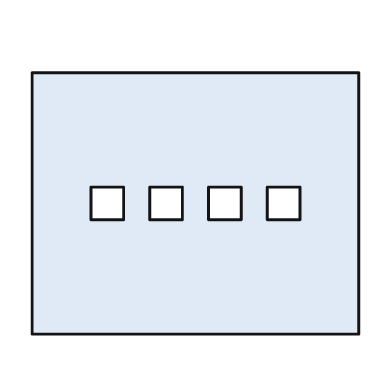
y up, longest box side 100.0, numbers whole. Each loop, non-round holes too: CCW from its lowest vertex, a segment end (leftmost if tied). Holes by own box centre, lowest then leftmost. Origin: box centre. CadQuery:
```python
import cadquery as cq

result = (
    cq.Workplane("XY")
    .moveTo(-50.0, -40.0)
    .lineTo(50.0, -40.0)
    .lineTo(50.0, 40.0)
    .lineTo(-50.0, 40.0)
    .close()
    .moveTo(-32.0, -5.0)
    .lineTo(-22.0, -5.0)
    .lineTo(-22.0, 5.0)
    .lineTo(-32.0, 5.0)
    .close()
    .moveTo(-14.0, -5.0)
    .lineTo(-4.0, -5.0)
    .lineTo(-4.0, 5.0)
    .lineTo(-14.0, 5.0)
    .close()
    .moveTo(4.0, -5.0)
    .lineTo(14.0, -5.0)
    .lineTo(14.0, 5.0)
    .lineTo(4.0, 5.0)
    .close()
    .moveTo(22.0, -5.0)
    .lineTo(32.0, -5.0)
    .lineTo(32.0, 5.0)
    .lineTo(22.0, 5.0)
    .close()
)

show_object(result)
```